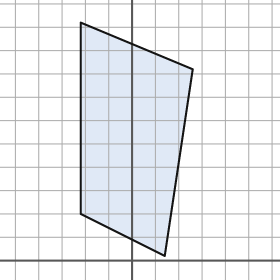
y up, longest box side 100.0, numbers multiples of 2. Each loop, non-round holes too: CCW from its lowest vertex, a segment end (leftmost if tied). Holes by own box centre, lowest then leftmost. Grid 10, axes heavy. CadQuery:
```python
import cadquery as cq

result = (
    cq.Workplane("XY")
    .moveTo(14.0, 2.0)
    .lineTo(26.0, 82.0)
    .lineTo(-22.0, 102.0)
    .lineTo(-22.0, 20.0)
    .close()
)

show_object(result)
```